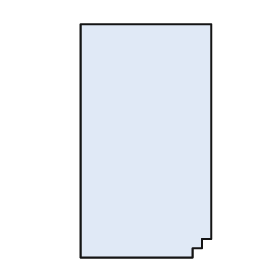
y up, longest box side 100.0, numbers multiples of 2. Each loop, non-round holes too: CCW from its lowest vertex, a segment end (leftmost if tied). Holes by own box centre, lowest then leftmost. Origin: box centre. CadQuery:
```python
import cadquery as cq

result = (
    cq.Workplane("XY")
    .moveTo(-28.0, -50.0)
    .lineTo(20.0, -50.0)
    .lineTo(20.0, -46.0)
    .lineTo(24.0, -46.0)
    .lineTo(24.0, -42.0)
    .lineTo(28.0, -42.0)
    .lineTo(28.0, 50.0)
    .lineTo(-28.0, 50.0)
    .close()
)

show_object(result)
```